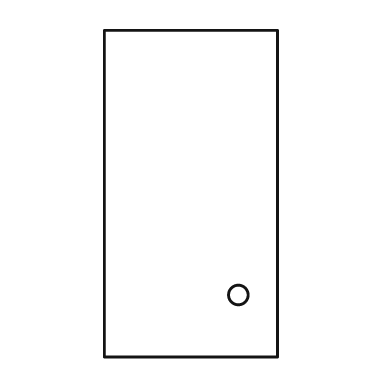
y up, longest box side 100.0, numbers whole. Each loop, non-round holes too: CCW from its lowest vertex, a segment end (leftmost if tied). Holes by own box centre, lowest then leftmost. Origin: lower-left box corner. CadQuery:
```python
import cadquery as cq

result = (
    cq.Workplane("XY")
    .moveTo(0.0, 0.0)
    .lineTo(53.0, 0.0)
    .lineTo(53.0, 100.0)
    .lineTo(0.0, 100.0)
    .close()
    .moveTo(41.0, 19.0)
    .circle(3.0)
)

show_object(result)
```